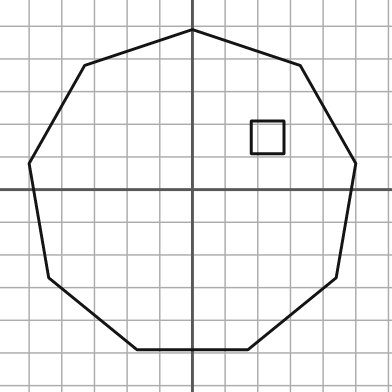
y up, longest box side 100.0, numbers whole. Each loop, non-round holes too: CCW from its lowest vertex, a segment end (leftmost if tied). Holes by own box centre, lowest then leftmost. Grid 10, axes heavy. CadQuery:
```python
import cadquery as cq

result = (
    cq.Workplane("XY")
    .moveTo(-17.0, -49.0)
    .lineTo(17.0, -49.0)
    .lineTo(44.0, -27.0)
    .lineTo(50.0, 8.0)
    .lineTo(33.0, 38.0)
    .lineTo(0.0, 49.0)
    .lineTo(-33.0, 38.0)
    .lineTo(-50.0, 8.0)
    .lineTo(-44.0, -27.0)
    .close()
    .moveTo(18.0, 11.0)
    .lineTo(28.0, 11.0)
    .lineTo(28.0, 21.0)
    .lineTo(18.0, 21.0)
    .close()
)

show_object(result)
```